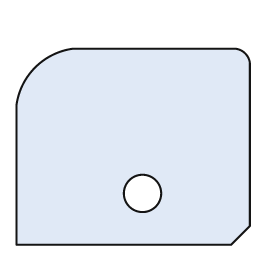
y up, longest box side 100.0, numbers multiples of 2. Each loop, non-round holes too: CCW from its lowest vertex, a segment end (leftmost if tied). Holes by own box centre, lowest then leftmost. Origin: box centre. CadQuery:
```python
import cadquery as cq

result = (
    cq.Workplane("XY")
    .moveTo(-50.0, -42.0)
    .lineTo(42.0, -42.0)
    .lineTo(50.0, -34.0)
    .lineTo(50.0, 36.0)
    .threePointArc((48.0, 40.0), (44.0, 42.0))
    .lineTo(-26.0, 42.0)
    .threePointArc((-42.0, 34.0), (-50.0, 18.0))
    .close()
    .moveTo(4.0, -20.0)
    .circle(8.0)
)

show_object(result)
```